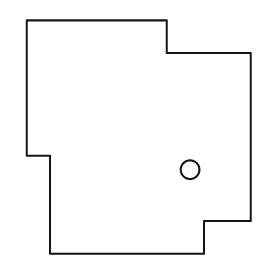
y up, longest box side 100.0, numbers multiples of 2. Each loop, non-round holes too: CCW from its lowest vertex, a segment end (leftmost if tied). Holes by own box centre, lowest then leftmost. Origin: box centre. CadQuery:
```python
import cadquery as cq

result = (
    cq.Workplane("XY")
    .moveTo(-38.0, -50.0)
    .lineTo(28.0, -50.0)
    .lineTo(28.0, -36.0)
    .lineTo(48.0, -36.0)
    .lineTo(48.0, 36.0)
    .lineTo(12.0, 36.0)
    .lineTo(12.0, 50.0)
    .lineTo(-48.0, 50.0)
    .lineTo(-48.0, -8.0)
    .lineTo(-38.0, -8.0)
    .close()
    .moveTo(22.0, -14.0)
    .circle(4.0)
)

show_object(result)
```